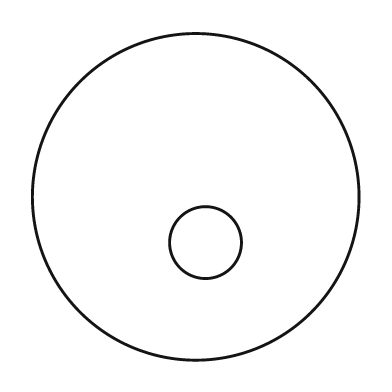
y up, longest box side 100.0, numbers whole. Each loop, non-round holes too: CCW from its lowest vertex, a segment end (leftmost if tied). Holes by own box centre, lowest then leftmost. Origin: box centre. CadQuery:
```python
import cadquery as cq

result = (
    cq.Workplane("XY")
    .moveTo(0.0, 0.0)
    .circle(50.0)
    .moveTo(3.0, -14.0)
    .circle(11.0)
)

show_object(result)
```